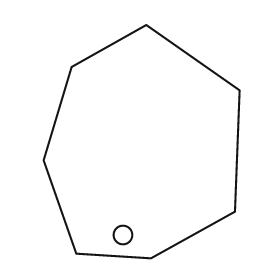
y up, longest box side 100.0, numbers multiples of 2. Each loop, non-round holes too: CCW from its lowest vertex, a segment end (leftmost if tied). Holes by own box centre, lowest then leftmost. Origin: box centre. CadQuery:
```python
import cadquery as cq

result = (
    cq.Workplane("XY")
    .moveTo(4.0, -50.0)
    .lineTo(40.0, -30.0)
    .lineTo(42.0, 22.0)
    .lineTo(2.0, 50.0)
    .lineTo(-30.0, 32.0)
    .lineTo(-42.0, -8.0)
    .lineTo(-28.0, -48.0)
    .close()
    .moveTo(-8.0, -40.0)
    .circle(4.0)
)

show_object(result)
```